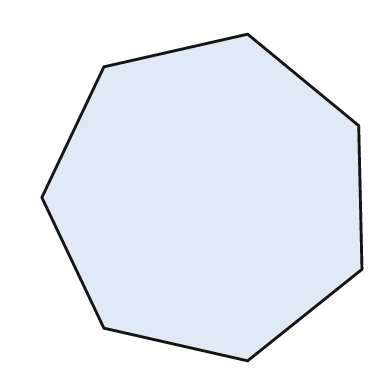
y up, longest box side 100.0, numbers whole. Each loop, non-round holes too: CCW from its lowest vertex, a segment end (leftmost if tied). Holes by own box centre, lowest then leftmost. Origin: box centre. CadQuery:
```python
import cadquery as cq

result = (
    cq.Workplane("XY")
    .moveTo(14.0, -50.0)
    .lineTo(49.0, -22.0)
    .lineTo(48.0, 22.0)
    .lineTo(14.0, 50.0)
    .lineTo(-30.0, 40.0)
    .lineTo(-49.0, 0.0)
    .lineTo(-30.0, -40.0)
    .close()
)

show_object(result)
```